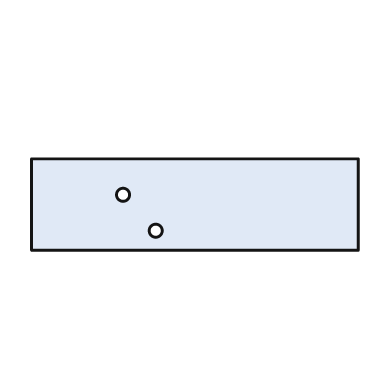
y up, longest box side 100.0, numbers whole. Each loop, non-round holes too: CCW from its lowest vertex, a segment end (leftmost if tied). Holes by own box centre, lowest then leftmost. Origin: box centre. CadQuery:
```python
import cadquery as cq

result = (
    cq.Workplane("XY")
    .moveTo(-50.0, -14.0)
    .lineTo(50.0, -14.0)
    .lineTo(50.0, 14.0)
    .lineTo(-50.0, 14.0)
    .close()
    .moveTo(-12.0, -8.0)
    .circle(2.0)
    .moveTo(-22.0, 3.0)
    .circle(2.0)
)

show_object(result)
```